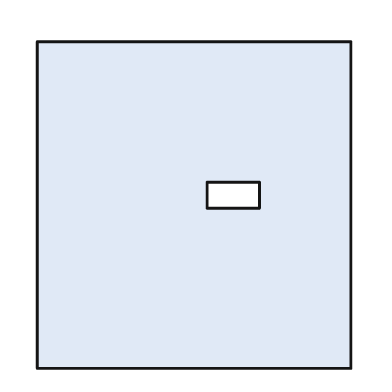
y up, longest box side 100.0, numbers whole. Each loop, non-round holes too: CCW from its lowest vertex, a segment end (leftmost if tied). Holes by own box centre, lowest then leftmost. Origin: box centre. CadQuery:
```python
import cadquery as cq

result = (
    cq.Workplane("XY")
    .moveTo(-48.0, -50.0)
    .lineTo(48.0, -50.0)
    .lineTo(48.0, 50.0)
    .lineTo(-48.0, 50.0)
    .close()
    .moveTo(4.0, -1.0)
    .lineTo(20.0, -1.0)
    .lineTo(20.0, 7.0)
    .lineTo(4.0, 7.0)
    .close()
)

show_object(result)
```